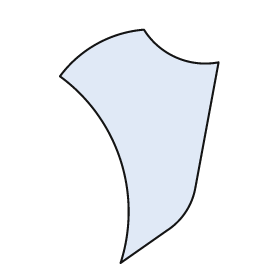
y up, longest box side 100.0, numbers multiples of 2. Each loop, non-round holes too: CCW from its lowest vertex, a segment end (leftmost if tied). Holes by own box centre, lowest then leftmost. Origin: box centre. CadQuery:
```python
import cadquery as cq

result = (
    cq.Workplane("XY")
    .moveTo(-8.0, -50.0)
    .lineTo(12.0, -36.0)
    .threePointArc((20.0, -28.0), (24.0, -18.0))
    .lineTo(34.0, 36.0)
    .threePointArc((16.0, 38.0), (2.0, 50.0))
    .threePointArc((-18.0, 44.0), (-34.0, 30.0))
    .threePointArc((-8.0, -6.0), (-8.0, -50.0))
    .close()
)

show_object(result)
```